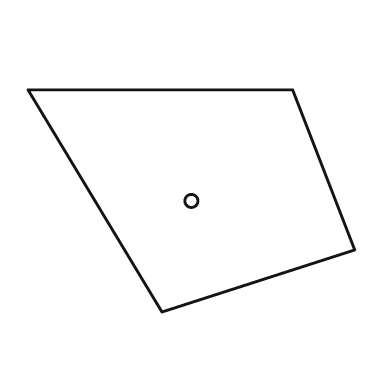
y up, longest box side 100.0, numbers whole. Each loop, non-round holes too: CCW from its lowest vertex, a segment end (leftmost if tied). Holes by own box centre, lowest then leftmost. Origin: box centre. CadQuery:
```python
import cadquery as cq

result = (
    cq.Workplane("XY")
    .moveTo(-9.0, -34.0)
    .lineTo(50.0, -15.0)
    .lineTo(31.0, 34.0)
    .lineTo(-50.0, 34.0)
    .close()
    .moveTo(0.0, 0.0)
    .circle(2.0)
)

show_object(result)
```